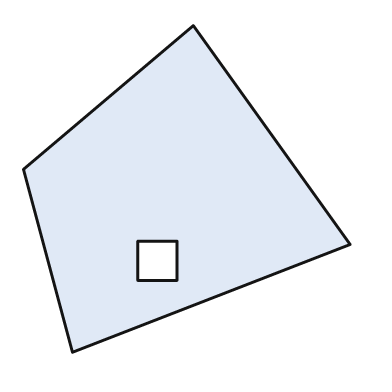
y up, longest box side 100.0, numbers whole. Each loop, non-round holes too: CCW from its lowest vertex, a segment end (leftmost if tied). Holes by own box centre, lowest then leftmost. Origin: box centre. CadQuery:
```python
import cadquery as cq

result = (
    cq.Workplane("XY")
    .moveTo(-35.0, -50.0)
    .lineTo(50.0, -17.0)
    .lineTo(2.0, 50.0)
    .lineTo(-50.0, 6.0)
    .close()
    .moveTo(-15.0, -28.0)
    .lineTo(-3.0, -28.0)
    .lineTo(-3.0, -16.0)
    .lineTo(-15.0, -16.0)
    .close()
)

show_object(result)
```